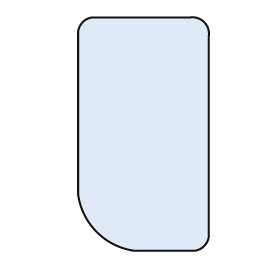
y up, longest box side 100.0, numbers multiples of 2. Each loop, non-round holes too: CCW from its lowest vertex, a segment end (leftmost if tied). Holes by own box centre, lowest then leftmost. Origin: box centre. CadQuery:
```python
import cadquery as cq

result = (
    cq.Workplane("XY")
    .moveTo(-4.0, -50.0)
    .lineTo(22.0, -50.0)
    .threePointArc((26.0, -48.0), (28.0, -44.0))
    .lineTo(28.0, 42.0)
    .threePointArc((26.0, 48.0), (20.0, 50.0))
    .lineTo(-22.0, 50.0)
    .threePointArc((-26.0, 48.0), (-28.0, 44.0))
    .lineTo(-28.0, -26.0)
    .threePointArc((-20.0, -42.0), (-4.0, -50.0))
    .close()
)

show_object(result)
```